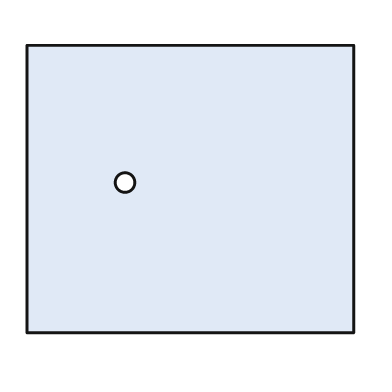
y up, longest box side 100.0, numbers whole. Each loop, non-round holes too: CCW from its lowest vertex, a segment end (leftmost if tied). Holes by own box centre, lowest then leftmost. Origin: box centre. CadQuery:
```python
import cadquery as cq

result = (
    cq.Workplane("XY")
    .moveTo(-50.0, -44.0)
    .lineTo(50.0, -44.0)
    .lineTo(50.0, 44.0)
    .lineTo(-50.0, 44.0)
    .close()
    .moveTo(-20.0, 2.0)
    .circle(3.0)
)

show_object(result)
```